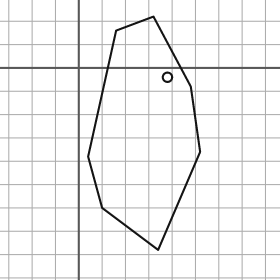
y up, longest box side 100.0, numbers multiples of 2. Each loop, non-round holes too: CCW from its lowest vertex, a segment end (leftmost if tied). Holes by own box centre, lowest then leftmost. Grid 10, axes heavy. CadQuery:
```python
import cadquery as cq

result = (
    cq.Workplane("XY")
    .moveTo(34.0, -78.0)
    .lineTo(52.0, -36.0)
    .lineTo(48.0, -8.0)
    .lineTo(32.0, 22.0)
    .lineTo(16.0, 16.0)
    .lineTo(4.0, -38.0)
    .lineTo(10.0, -60.0)
    .close()
    .moveTo(38.0, -4.0)
    .circle(2.0)
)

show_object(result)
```